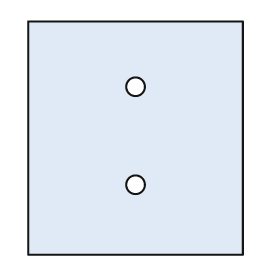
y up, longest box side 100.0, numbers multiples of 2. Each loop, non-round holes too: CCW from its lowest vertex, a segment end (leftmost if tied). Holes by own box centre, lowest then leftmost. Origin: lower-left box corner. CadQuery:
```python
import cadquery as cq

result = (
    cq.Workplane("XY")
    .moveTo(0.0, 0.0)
    .lineTo(92.0, 0.0)
    .lineTo(92.0, 100.0)
    .lineTo(0.0, 100.0)
    .close()
    .moveTo(46.0, 30.0)
    .circle(4.0)
    .moveTo(46.0, 72.0)
    .circle(4.0)
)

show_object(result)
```